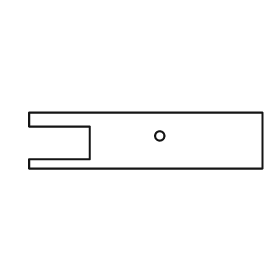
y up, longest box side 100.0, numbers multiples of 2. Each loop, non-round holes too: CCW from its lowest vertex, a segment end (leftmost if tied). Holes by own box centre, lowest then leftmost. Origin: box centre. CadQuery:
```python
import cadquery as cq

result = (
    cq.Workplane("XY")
    .moveTo(-50.0, -12.0)
    .lineTo(50.0, -12.0)
    .lineTo(50.0, 12.0)
    .lineTo(-50.0, 12.0)
    .lineTo(-50.0, 6.0)
    .lineTo(-24.0, 6.0)
    .lineTo(-24.0, -8.0)
    .lineTo(-50.0, -8.0)
    .close()
    .moveTo(6.0, 2.0)
    .circle(2.0)
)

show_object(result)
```